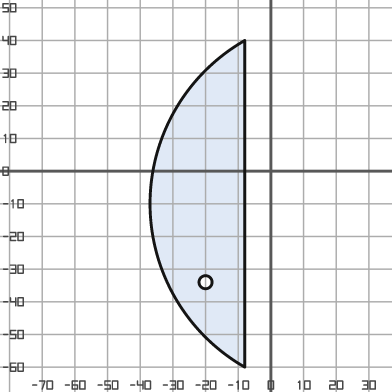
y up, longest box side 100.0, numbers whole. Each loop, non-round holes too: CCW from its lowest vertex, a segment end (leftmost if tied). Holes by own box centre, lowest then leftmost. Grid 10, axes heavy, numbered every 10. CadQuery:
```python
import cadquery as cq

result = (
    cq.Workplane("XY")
    .moveTo(-8.0, -60.0)
    .lineTo(-8.0, 40.0)
    .threePointArc((-37.0, -10.0), (-8.0, -60.0))
    .close()
    .moveTo(-20.0, -34.0)
    .circle(2.0)
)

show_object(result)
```